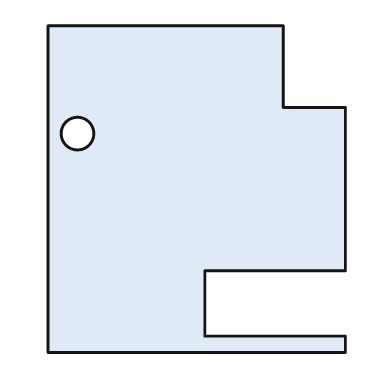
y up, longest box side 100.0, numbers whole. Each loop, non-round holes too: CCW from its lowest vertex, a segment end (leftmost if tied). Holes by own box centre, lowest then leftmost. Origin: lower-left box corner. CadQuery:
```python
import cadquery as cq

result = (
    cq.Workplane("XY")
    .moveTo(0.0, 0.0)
    .lineTo(91.0, 0.0)
    .lineTo(91.0, 5.0)
    .lineTo(48.0, 5.0)
    .lineTo(48.0, 25.0)
    .lineTo(91.0, 25.0)
    .lineTo(91.0, 75.0)
    .lineTo(72.0, 75.0)
    .lineTo(72.0, 100.0)
    .lineTo(0.0, 100.0)
    .close()
    .moveTo(9.0, 67.0)
    .circle(5.0)
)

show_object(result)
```